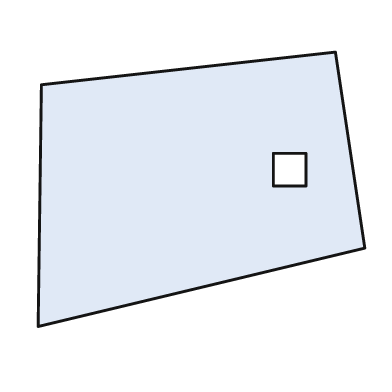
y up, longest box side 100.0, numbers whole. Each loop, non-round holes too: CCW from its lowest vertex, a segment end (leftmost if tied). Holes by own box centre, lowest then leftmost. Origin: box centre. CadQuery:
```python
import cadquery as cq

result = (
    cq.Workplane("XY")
    .moveTo(-50.0, -42.0)
    .lineTo(50.0, -18.0)
    .lineTo(41.0, 42.0)
    .lineTo(-49.0, 32.0)
    .close()
    .moveTo(22.0, 1.0)
    .lineTo(32.0, 1.0)
    .lineTo(32.0, 11.0)
    .lineTo(22.0, 11.0)
    .close()
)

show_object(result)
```